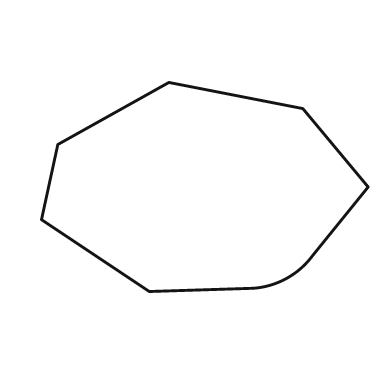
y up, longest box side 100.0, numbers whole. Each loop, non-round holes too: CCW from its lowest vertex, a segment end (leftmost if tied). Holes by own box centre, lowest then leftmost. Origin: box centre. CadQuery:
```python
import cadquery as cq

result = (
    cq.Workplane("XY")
    .moveTo(-17.0, -32.0)
    .lineTo(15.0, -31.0)
    .threePointArc((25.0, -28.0), (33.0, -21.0))
    .lineTo(50.0, 0.0)
    .lineTo(30.0, 24.0)
    .lineTo(-11.0, 32.0)
    .lineTo(-45.0, 13.0)
    .lineTo(-50.0, -10.0)
    .close()
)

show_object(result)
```